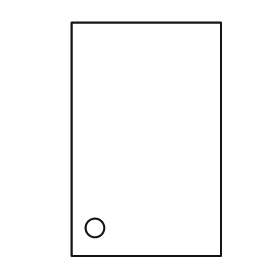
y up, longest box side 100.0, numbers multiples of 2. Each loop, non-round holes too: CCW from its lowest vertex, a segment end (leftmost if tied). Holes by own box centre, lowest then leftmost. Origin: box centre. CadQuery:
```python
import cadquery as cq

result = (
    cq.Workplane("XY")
    .moveTo(-32.0, -50.0)
    .lineTo(32.0, -50.0)
    .lineTo(32.0, 50.0)
    .lineTo(-32.0, 50.0)
    .close()
    .moveTo(-22.0, -38.0)
    .circle(4.0)
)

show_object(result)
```